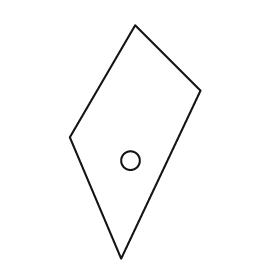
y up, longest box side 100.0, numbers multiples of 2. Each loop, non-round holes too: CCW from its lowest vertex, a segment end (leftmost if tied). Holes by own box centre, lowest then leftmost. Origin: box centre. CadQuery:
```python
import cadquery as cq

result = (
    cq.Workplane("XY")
    .moveTo(-6.0, -50.0)
    .lineTo(28.0, 22.0)
    .lineTo(0.0, 50.0)
    .lineTo(-28.0, 2.0)
    .close()
    .moveTo(-2.0, -8.0)
    .circle(4.0)
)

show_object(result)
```